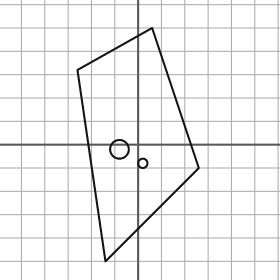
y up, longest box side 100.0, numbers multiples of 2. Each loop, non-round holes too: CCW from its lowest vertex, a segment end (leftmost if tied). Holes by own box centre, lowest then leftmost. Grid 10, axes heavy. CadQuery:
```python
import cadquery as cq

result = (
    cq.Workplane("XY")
    .moveTo(-14.0, -50.0)
    .lineTo(26.0, -10.0)
    .lineTo(6.0, 50.0)
    .lineTo(-26.0, 32.0)
    .close()
    .moveTo(2.0, -8.0)
    .circle(2.0)
    .moveTo(-8.0, -2.0)
    .circle(4.0)
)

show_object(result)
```